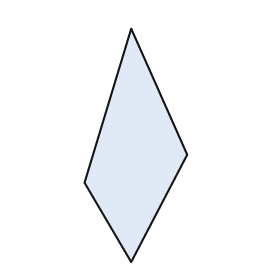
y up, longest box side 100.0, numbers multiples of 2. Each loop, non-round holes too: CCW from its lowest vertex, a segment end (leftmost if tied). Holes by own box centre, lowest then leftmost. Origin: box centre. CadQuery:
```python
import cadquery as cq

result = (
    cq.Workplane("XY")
    .moveTo(-2.0, -50.0)
    .lineTo(22.0, -4.0)
    .lineTo(-2.0, 50.0)
    .lineTo(-22.0, -16.0)
    .close()
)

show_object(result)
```